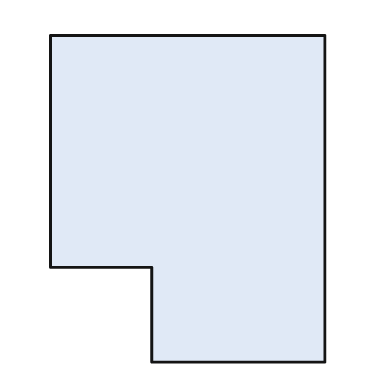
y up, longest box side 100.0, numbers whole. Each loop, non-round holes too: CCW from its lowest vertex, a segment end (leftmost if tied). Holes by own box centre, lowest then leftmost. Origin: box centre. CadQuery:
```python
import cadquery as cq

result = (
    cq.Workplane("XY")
    .moveTo(-11.0, -50.0)
    .lineTo(42.0, -50.0)
    .lineTo(42.0, 50.0)
    .lineTo(-42.0, 50.0)
    .lineTo(-42.0, -21.0)
    .lineTo(-11.0, -21.0)
    .close()
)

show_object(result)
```